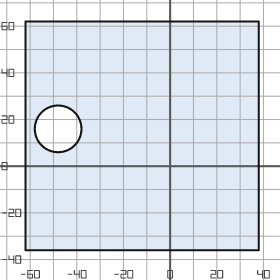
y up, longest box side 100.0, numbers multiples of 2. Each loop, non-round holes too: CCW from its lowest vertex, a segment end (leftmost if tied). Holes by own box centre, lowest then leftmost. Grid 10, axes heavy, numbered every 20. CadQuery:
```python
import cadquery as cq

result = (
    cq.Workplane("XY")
    .moveTo(-62.0, -36.0)
    .lineTo(38.0, -36.0)
    .lineTo(38.0, 62.0)
    .lineTo(-62.0, 62.0)
    .close()
    .moveTo(-48.0, 16.0)
    .circle(10.0)
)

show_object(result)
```